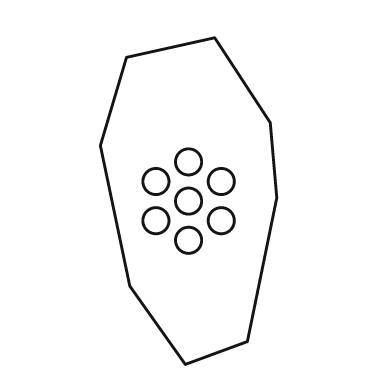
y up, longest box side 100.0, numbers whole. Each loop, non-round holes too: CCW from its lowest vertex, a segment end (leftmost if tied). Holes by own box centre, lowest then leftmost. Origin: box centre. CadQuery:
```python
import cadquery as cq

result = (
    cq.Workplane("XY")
    .moveTo(-1.0, -50.0)
    .lineTo(18.0, -43.0)
    .lineTo(27.0, 1.0)
    .lineTo(25.0, 24.0)
    .lineTo(8.0, 50.0)
    .lineTo(-19.0, 44.0)
    .lineTo(-27.0, 17.0)
    .lineTo(-18.0, -26.0)
    .close()
    .moveTo(0.0, -12.0)
    .circle(4.0)
    .moveTo(-10.0, -6.0)
    .circle(4.0)
    .moveTo(10.0, -6.0)
    .circle(4.0)
    .moveTo(0.0, 0.0)
    .circle(4.0)
    .moveTo(-10.0, 6.0)
    .circle(4.0)
    .moveTo(10.0, 6.0)
    .circle(4.0)
    .moveTo(0.0, 12.0)
    .circle(4.0)
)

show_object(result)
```